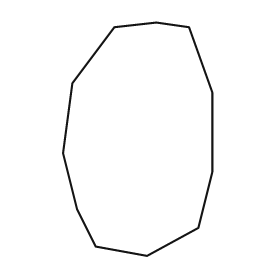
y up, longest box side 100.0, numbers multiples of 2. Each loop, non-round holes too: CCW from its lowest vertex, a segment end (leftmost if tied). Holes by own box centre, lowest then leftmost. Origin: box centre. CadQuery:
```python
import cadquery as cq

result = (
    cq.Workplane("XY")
    .moveTo(4.0, -50.0)
    .lineTo(26.0, -38.0)
    .lineTo(32.0, -14.0)
    .lineTo(32.0, 20.0)
    .lineTo(22.0, 48.0)
    .lineTo(8.0, 50.0)
    .lineTo(-10.0, 48.0)
    .lineTo(-28.0, 24.0)
    .lineTo(-32.0, -6.0)
    .lineTo(-26.0, -30.0)
    .lineTo(-18.0, -46.0)
    .close()
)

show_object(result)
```